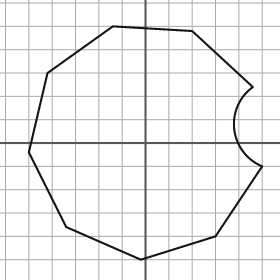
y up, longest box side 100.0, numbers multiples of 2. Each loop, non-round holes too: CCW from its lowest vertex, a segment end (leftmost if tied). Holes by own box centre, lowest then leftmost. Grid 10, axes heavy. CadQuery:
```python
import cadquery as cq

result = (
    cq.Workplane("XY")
    .moveTo(-2.0, -50.0)
    .lineTo(30.0, -40.0)
    .lineTo(50.0, -10.0)
    .threePointArc((38.0, 6.0), (46.0, 24.0))
    .lineTo(20.0, 48.0)
    .lineTo(-14.0, 50.0)
    .lineTo(-42.0, 30.0)
    .lineTo(-50.0, -4.0)
    .lineTo(-34.0, -36.0)
    .close()
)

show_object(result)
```